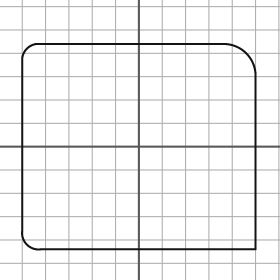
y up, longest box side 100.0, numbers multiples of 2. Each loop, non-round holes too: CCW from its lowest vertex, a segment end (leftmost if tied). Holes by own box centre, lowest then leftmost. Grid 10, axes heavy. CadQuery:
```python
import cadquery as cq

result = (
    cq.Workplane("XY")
    .moveTo(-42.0, -44.0)
    .lineTo(50.0, -44.0)
    .lineTo(50.0, 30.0)
    .threePointArc((46.0, 40.0), (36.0, 44.0))
    .lineTo(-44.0, 44.0)
    .threePointArc((-48.0, 42.0), (-50.0, 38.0))
    .lineTo(-50.0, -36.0)
    .threePointArc((-48.0, -42.0), (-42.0, -44.0))
    .close()
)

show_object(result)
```